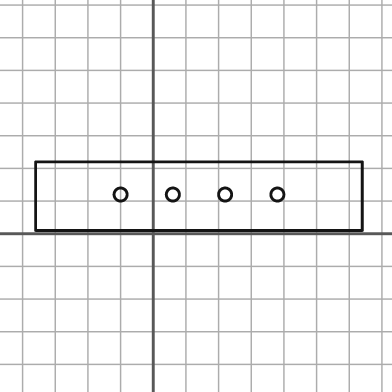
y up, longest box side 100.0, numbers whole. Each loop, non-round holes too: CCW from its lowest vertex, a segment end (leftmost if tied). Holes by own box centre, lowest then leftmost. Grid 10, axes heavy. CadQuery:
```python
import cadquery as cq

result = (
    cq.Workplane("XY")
    .moveTo(-36.0, 1.0)
    .lineTo(64.0, 1.0)
    .lineTo(64.0, 22.0)
    .lineTo(-36.0, 22.0)
    .close()
    .moveTo(-10.0, 12.0)
    .circle(2.0)
    .moveTo(6.0, 12.0)
    .circle(2.0)
    .moveTo(22.0, 12.0)
    .circle(2.0)
    .moveTo(38.0, 12.0)
    .circle(2.0)
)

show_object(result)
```